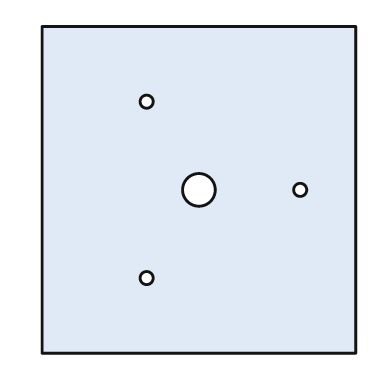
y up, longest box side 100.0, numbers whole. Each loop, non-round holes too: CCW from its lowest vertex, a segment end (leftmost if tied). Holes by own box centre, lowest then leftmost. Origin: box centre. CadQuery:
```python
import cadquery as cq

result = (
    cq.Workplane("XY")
    .moveTo(-48.0, -50.0)
    .lineTo(48.0, -50.0)
    .lineTo(48.0, 50.0)
    .lineTo(-48.0, 50.0)
    .close()
    .moveTo(-16.0, -27.0)
    .circle(2.0)
    .moveTo(0.0, 0.0)
    .circle(5.0)
    .moveTo(31.0, 0.0)
    .circle(2.0)
    .moveTo(-16.0, 27.0)
    .circle(2.0)
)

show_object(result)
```